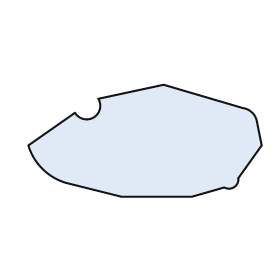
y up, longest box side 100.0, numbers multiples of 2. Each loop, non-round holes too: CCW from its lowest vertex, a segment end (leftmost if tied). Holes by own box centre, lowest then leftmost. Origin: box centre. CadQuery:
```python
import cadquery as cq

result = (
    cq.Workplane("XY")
    .moveTo(-10.0, -24.0)
    .lineTo(20.0, -24.0)
    .lineTo(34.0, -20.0)
    .threePointArc((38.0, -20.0), (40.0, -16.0))
    .lineTo(50.0, -2.0)
    .lineTo(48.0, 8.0)
    .threePointArc((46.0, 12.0), (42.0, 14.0))
    .lineTo(8.0, 24.0)
    .lineTo(-20.0, 18.0)
    .threePointArc((-22.0, 10.0), (-30.0, 12.0))
    .lineTo(-50.0, -2.0)
    .threePointArc((-44.0, -12.0), (-34.0, -18.0))
    .close()
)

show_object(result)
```